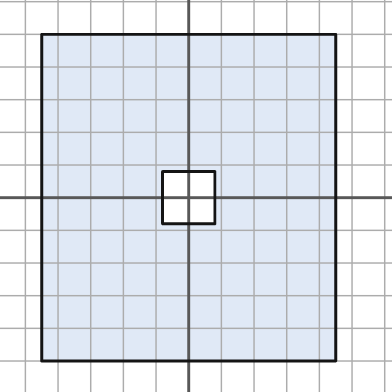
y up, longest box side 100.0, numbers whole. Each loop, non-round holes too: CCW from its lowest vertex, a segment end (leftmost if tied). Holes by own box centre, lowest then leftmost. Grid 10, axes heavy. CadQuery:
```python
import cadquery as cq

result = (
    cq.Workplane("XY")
    .moveTo(-45.0, -50.0)
    .lineTo(45.0, -50.0)
    .lineTo(45.0, 50.0)
    .lineTo(-45.0, 50.0)
    .close()
    .moveTo(-8.0, -8.0)
    .lineTo(8.0, -8.0)
    .lineTo(8.0, 8.0)
    .lineTo(-8.0, 8.0)
    .close()
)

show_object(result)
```